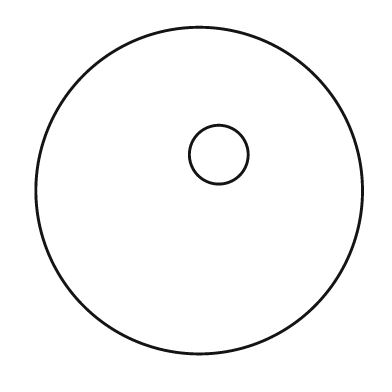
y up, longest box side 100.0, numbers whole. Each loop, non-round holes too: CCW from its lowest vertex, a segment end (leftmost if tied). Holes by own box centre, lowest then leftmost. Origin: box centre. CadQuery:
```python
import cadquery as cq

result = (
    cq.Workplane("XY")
    .moveTo(0.0, 0.0)
    .circle(50.0)
    .moveTo(6.0, 11.0)
    .circle(9.0)
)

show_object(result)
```